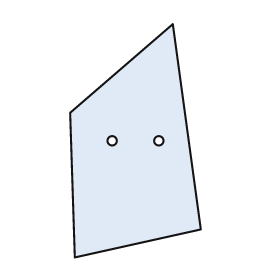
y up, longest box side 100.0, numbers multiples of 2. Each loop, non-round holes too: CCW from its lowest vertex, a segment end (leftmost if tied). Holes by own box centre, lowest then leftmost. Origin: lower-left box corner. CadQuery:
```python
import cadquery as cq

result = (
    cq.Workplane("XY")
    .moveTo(2.0, 0.0)
    .lineTo(56.0, 12.0)
    .lineTo(44.0, 100.0)
    .lineTo(0.0, 62.0)
    .close()
    .moveTo(18.0, 50.0)
    .circle(2.0)
    .moveTo(38.0, 50.0)
    .circle(2.0)
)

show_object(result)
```